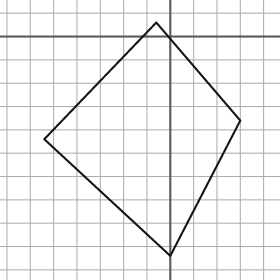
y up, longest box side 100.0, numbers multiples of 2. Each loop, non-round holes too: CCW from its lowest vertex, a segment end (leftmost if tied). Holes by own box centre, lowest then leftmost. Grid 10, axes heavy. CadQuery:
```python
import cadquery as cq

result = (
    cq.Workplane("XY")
    .moveTo(0.0, -94.0)
    .lineTo(30.0, -36.0)
    .lineTo(-6.0, 6.0)
    .lineTo(-54.0, -44.0)
    .close()
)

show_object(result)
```